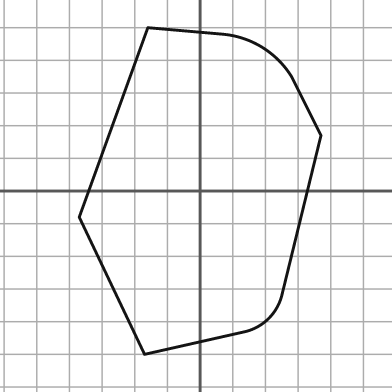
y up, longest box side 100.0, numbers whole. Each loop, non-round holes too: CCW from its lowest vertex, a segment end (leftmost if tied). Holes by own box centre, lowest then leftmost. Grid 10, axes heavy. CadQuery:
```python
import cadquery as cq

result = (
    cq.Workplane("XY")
    .moveTo(-17.0, -50.0)
    .lineTo(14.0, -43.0)
    .threePointArc((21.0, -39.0), (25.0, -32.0))
    .lineTo(37.0, 17.0)
    .lineTo(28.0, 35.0)
    .threePointArc((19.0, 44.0), (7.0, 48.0))
    .lineTo(-16.0, 50.0)
    .lineTo(-37.0, -8.0)
    .close()
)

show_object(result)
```